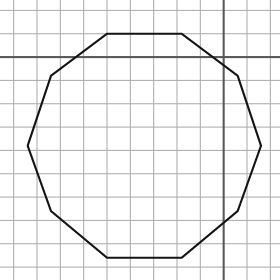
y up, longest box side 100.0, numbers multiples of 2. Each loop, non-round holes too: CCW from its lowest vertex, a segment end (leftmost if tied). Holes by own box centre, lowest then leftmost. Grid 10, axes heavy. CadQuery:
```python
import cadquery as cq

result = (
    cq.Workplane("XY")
    .moveTo(-50.0, -86.0)
    .lineTo(-18.0, -86.0)
    .lineTo(6.0, -66.0)
    .lineTo(16.0, -38.0)
    .lineTo(6.0, -8.0)
    .lineTo(-18.0, 10.0)
    .lineTo(-50.0, 10.0)
    .lineTo(-74.0, -8.0)
    .lineTo(-84.0, -38.0)
    .lineTo(-74.0, -66.0)
    .close()
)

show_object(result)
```